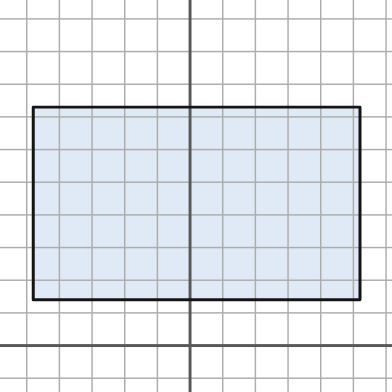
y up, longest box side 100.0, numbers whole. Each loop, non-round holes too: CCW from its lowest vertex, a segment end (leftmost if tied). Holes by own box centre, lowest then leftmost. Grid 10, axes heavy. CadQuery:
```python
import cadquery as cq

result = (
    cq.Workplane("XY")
    .moveTo(-48.0, 14.0)
    .lineTo(52.0, 14.0)
    .lineTo(52.0, 73.0)
    .lineTo(-48.0, 73.0)
    .close()
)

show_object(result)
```